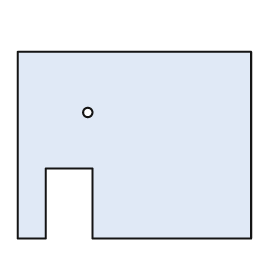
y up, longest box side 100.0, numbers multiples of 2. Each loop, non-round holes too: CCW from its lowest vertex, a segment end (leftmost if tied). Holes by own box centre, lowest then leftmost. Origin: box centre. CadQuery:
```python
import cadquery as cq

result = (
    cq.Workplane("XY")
    .moveTo(-50.0, -40.0)
    .lineTo(-38.0, -40.0)
    .lineTo(-38.0, -10.0)
    .lineTo(-18.0, -10.0)
    .lineTo(-18.0, -40.0)
    .lineTo(50.0, -40.0)
    .lineTo(50.0, 40.0)
    .lineTo(-50.0, 40.0)
    .close()
    .moveTo(-20.0, 14.0)
    .circle(2.0)
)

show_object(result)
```